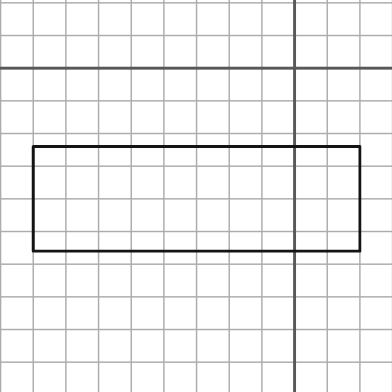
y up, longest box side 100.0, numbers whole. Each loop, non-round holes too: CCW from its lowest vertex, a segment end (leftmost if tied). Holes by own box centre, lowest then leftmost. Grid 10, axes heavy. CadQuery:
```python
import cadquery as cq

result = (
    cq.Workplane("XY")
    .moveTo(-80.0, -56.0)
    .lineTo(20.0, -56.0)
    .lineTo(20.0, -24.0)
    .lineTo(-80.0, -24.0)
    .close()
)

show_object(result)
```